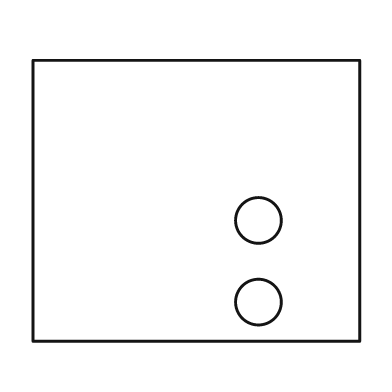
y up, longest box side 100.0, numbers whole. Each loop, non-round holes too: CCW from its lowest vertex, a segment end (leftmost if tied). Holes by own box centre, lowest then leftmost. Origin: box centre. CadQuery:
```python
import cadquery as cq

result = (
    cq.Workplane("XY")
    .moveTo(-50.0, -43.0)
    .lineTo(50.0, -43.0)
    .lineTo(50.0, 43.0)
    .lineTo(-50.0, 43.0)
    .close()
    .moveTo(19.0, -31.0)
    .circle(7.0)
    .moveTo(19.0, -6.0)
    .circle(7.0)
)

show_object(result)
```